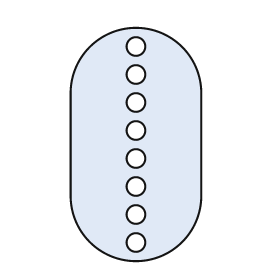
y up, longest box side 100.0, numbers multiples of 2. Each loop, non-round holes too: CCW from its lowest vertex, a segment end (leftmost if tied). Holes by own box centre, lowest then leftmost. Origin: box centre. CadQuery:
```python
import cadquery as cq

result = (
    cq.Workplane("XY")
    .moveTo(-28.0, -22.0)
    .threePointArc((0.0, -50.0), (28.0, -22.0))
    .lineTo(28.0, 22.0)
    .threePointArc((0.0, 50.0), (-28.0, 22.0))
    .close()
    .moveTo(0.0, -42.0)
    .circle(4.0)
    .moveTo(0.0, -30.0)
    .circle(4.0)
    .moveTo(0.0, -18.0)
    .circle(4.0)
    .moveTo(0.0, -6.0)
    .circle(4.0)
    .moveTo(0.0, 6.0)
    .circle(4.0)
    .moveTo(0.0, 18.0)
    .circle(4.0)
    .moveTo(0.0, 30.0)
    .circle(4.0)
    .moveTo(0.0, 42.0)
    .circle(4.0)
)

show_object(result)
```